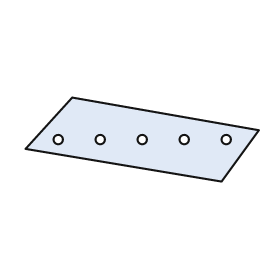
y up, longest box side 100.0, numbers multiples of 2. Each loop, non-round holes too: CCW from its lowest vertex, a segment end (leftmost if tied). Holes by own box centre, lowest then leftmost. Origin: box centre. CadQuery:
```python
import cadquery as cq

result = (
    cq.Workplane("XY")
    .moveTo(34.0, -18.0)
    .lineTo(50.0, 4.0)
    .lineTo(-30.0, 18.0)
    .lineTo(-50.0, -4.0)
    .close()
    .moveTo(-36.0, 0.0)
    .circle(2.0)
    .moveTo(-18.0, 0.0)
    .circle(2.0)
    .moveTo(0.0, 0.0)
    .circle(2.0)
    .moveTo(18.0, 0.0)
    .circle(2.0)
    .moveTo(36.0, 0.0)
    .circle(2.0)
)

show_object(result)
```